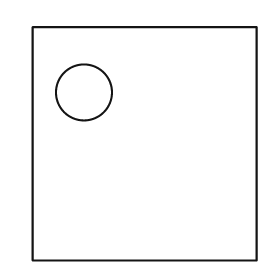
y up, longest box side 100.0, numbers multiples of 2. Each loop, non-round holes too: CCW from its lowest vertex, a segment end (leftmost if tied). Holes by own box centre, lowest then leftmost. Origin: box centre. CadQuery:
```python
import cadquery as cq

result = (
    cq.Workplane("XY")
    .moveTo(-48.0, -50.0)
    .lineTo(48.0, -50.0)
    .lineTo(48.0, 50.0)
    .lineTo(-48.0, 50.0)
    .close()
    .moveTo(-26.0, 22.0)
    .circle(12.0)
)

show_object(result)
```